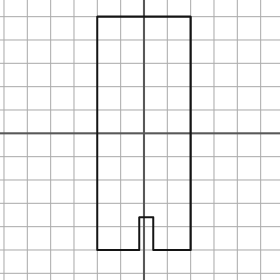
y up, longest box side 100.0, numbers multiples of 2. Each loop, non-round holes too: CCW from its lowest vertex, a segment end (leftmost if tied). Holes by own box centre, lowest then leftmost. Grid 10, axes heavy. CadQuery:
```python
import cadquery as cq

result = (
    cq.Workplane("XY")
    .moveTo(-20.0, -50.0)
    .lineTo(-2.0, -50.0)
    .lineTo(-2.0, -36.0)
    .lineTo(4.0, -36.0)
    .lineTo(4.0, -50.0)
    .lineTo(20.0, -50.0)
    .lineTo(20.0, 50.0)
    .lineTo(-20.0, 50.0)
    .close()
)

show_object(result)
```